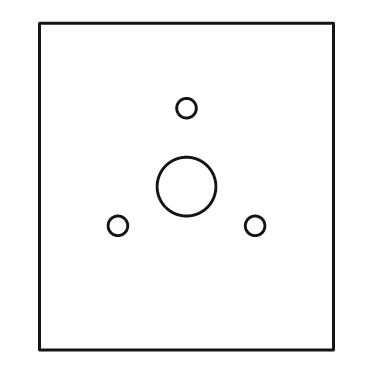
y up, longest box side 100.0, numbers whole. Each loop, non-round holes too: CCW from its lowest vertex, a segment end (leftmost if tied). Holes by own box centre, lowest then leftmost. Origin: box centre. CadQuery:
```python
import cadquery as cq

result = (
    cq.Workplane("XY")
    .moveTo(-45.0, -50.0)
    .lineTo(45.0, -50.0)
    .lineTo(45.0, 50.0)
    .lineTo(-45.0, 50.0)
    .close()
    .moveTo(-21.0, -12.0)
    .circle(3.0)
    .moveTo(21.0, -12.0)
    .circle(3.0)
    .moveTo(0.0, 0.0)
    .circle(9.0)
    .moveTo(0.0, 24.0)
    .circle(3.0)
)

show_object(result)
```